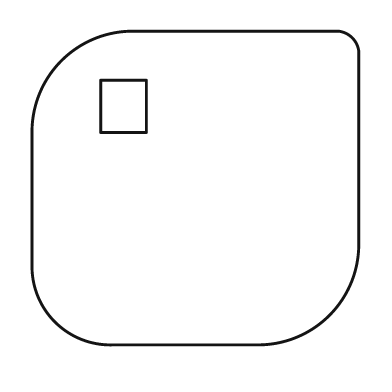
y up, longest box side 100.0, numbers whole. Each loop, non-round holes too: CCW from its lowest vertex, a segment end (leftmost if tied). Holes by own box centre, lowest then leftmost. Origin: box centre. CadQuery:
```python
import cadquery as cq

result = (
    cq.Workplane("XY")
    .moveTo(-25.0, -48.0)
    .lineTo(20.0, -48.0)
    .threePointArc((41.0, -39.0), (50.0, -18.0))
    .lineTo(50.0, 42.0)
    .threePointArc((48.0, 46.0), (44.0, 48.0))
    .lineTo(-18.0, 48.0)
    .threePointArc((-41.0, 39.0), (-50.0, 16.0))
    .lineTo(-50.0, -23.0)
    .threePointArc((-43.0, -41.0), (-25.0, -48.0))
    .close()
    .moveTo(-29.0, 17.0)
    .lineTo(-15.0, 17.0)
    .lineTo(-15.0, 33.0)
    .lineTo(-29.0, 33.0)
    .close()
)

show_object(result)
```